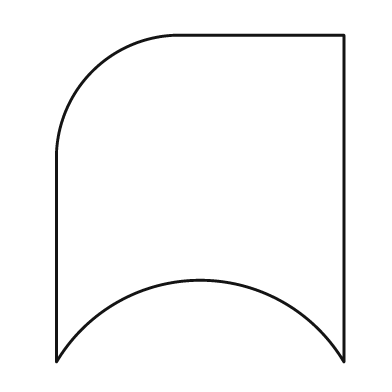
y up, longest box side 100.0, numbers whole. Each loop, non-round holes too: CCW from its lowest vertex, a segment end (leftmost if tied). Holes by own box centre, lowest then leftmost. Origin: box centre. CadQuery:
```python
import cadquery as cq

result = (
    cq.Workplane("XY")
    .moveTo(-44.0, -50.0)
    .threePointArc((0.0, -25.0), (44.0, -50.0))
    .lineTo(44.0, 50.0)
    .lineTo(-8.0, 50.0)
    .threePointArc((-33.0, 39.0), (-44.0, 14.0))
    .close()
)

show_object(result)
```